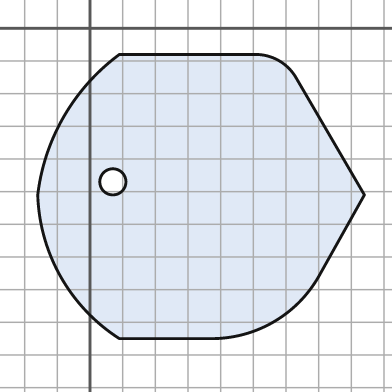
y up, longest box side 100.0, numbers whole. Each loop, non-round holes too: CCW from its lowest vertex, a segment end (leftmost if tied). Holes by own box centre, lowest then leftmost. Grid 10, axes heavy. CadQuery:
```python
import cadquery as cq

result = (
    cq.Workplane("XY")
    .moveTo(9.0, -95.0)
    .lineTo(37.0, -95.0)
    .threePointArc((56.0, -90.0), (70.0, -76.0))
    .lineTo(84.0, -51.0)
    .lineTo(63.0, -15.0)
    .threePointArc((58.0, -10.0), (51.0, -8.0))
    .lineTo(9.0, -8.0)
    .threePointArc((-8.0, -27.0), (-16.0, -51.0))
    .threePointArc((-9.0, -76.0), (9.0, -95.0))
    .close()
    .moveTo(7.0, -47.0)
    .circle(4.0)
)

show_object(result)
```